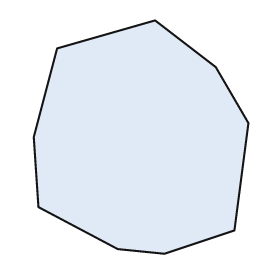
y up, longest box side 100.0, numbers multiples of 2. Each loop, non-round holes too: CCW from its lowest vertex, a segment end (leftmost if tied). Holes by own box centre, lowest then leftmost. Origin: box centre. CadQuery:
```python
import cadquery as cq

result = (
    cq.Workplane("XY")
    .moveTo(10.0, -50.0)
    .lineTo(40.0, -40.0)
    .lineTo(46.0, 6.0)
    .lineTo(32.0, 30.0)
    .lineTo(6.0, 50.0)
    .lineTo(-36.0, 38.0)
    .lineTo(-46.0, 0.0)
    .lineTo(-44.0, -30.0)
    .lineTo(-10.0, -48.0)
    .close()
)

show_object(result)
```